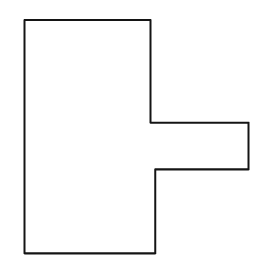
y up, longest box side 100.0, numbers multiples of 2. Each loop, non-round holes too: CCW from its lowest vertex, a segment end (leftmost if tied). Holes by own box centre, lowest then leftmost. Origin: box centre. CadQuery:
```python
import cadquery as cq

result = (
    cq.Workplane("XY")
    .moveTo(-48.0, -50.0)
    .lineTo(8.0, -50.0)
    .lineTo(8.0, -14.0)
    .lineTo(48.0, -14.0)
    .lineTo(48.0, 6.0)
    .lineTo(6.0, 6.0)
    .lineTo(6.0, 50.0)
    .lineTo(-48.0, 50.0)
    .close()
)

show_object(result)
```